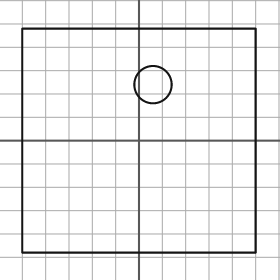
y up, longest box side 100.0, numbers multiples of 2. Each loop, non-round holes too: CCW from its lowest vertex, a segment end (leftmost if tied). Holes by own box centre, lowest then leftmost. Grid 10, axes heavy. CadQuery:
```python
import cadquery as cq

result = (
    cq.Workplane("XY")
    .moveTo(-50.0, -48.0)
    .lineTo(50.0, -48.0)
    .lineTo(50.0, 48.0)
    .lineTo(-50.0, 48.0)
    .close()
    .moveTo(6.0, 24.0)
    .circle(8.0)
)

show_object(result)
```